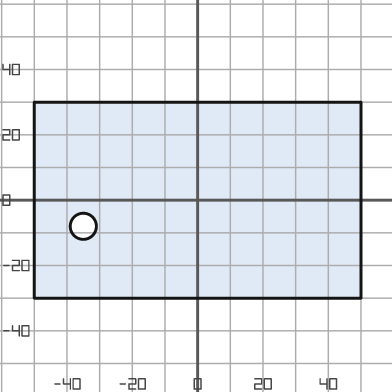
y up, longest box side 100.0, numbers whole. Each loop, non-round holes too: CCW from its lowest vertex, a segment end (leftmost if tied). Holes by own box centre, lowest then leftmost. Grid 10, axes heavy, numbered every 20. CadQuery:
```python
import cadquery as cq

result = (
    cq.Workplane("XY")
    .moveTo(-50.0, -30.0)
    .lineTo(50.0, -30.0)
    .lineTo(50.0, 30.0)
    .lineTo(-50.0, 30.0)
    .close()
    .moveTo(-35.0, -8.0)
    .circle(4.0)
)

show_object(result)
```